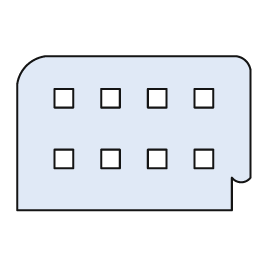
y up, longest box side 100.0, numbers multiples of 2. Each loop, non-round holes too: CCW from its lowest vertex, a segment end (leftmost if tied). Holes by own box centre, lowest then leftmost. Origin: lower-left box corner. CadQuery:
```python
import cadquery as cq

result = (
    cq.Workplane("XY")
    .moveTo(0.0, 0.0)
    .lineTo(92.0, 0.0)
    .lineTo(92.0, 14.0)
    .threePointArc((96.0, 12.0), (100.0, 14.0))
    .lineTo(100.0, 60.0)
    .threePointArc((98.0, 64.0), (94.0, 66.0))
    .lineTo(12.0, 66.0)
    .threePointArc((4.0, 62.0), (0.0, 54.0))
    .close()
    .moveTo(16.0, 18.0)
    .lineTo(24.0, 18.0)
    .lineTo(24.0, 26.0)
    .lineTo(16.0, 26.0)
    .close()
    .moveTo(36.0, 18.0)
    .lineTo(44.0, 18.0)
    .lineTo(44.0, 26.0)
    .lineTo(36.0, 26.0)
    .close()
    .moveTo(56.0, 18.0)
    .lineTo(64.0, 18.0)
    .lineTo(64.0, 26.0)
    .lineTo(56.0, 26.0)
    .close()
    .moveTo(76.0, 18.0)
    .lineTo(84.0, 18.0)
    .lineTo(84.0, 26.0)
    .lineTo(76.0, 26.0)
    .close()
    .moveTo(16.0, 44.0)
    .lineTo(24.0, 44.0)
    .lineTo(24.0, 52.0)
    .lineTo(16.0, 52.0)
    .close()
    .moveTo(36.0, 44.0)
    .lineTo(44.0, 44.0)
    .lineTo(44.0, 52.0)
    .lineTo(36.0, 52.0)
    .close()
    .moveTo(56.0, 44.0)
    .lineTo(64.0, 44.0)
    .lineTo(64.0, 52.0)
    .lineTo(56.0, 52.0)
    .close()
    .moveTo(76.0, 44.0)
    .lineTo(84.0, 44.0)
    .lineTo(84.0, 52.0)
    .lineTo(76.0, 52.0)
    .close()
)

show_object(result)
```